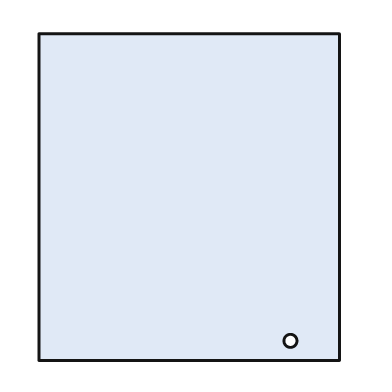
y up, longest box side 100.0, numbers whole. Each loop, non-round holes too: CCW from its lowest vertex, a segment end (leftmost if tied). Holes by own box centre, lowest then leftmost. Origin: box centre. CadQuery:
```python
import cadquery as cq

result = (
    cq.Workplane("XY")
    .moveTo(-46.0, -50.0)
    .lineTo(46.0, -50.0)
    .lineTo(46.0, 50.0)
    .lineTo(-46.0, 50.0)
    .close()
    .moveTo(31.0, -44.0)
    .circle(2.0)
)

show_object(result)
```